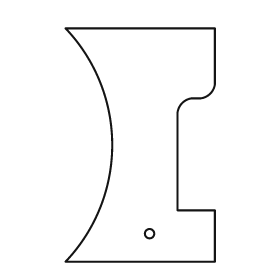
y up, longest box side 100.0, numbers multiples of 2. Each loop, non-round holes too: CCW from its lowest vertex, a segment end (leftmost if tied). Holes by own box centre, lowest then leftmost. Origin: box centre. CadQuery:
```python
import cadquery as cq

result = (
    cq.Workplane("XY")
    .moveTo(-32.0, -50.0)
    .lineTo(32.0, -50.0)
    .lineTo(32.0, -28.0)
    .lineTo(16.0, -28.0)
    .lineTo(16.0, 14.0)
    .threePointArc((18.0, 18.0), (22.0, 20.0))
    .lineTo(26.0, 20.0)
    .threePointArc((30.0, 22.0), (32.0, 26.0))
    .lineTo(32.0, 50.0)
    .lineTo(-32.0, 50.0)
    .threePointArc((-12.0, 0.0), (-32.0, -50.0))
    .close()
    .moveTo(4.0, -38.0)
    .circle(2.0)
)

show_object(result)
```